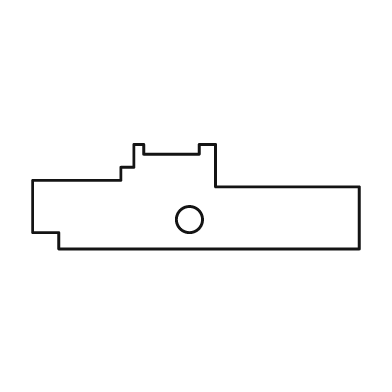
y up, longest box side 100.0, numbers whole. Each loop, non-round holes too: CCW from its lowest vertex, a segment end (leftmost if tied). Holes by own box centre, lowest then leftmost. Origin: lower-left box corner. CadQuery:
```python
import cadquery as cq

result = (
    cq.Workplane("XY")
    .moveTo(8.0, 0.0)
    .lineTo(100.0, 0.0)
    .lineTo(100.0, 19.0)
    .lineTo(56.0, 19.0)
    .lineTo(56.0, 32.0)
    .lineTo(51.0, 32.0)
    .lineTo(51.0, 29.0)
    .lineTo(34.0, 29.0)
    .lineTo(34.0, 32.0)
    .lineTo(31.0, 32.0)
    .lineTo(31.0, 25.0)
    .lineTo(27.0, 25.0)
    .lineTo(27.0, 21.0)
    .lineTo(0.0, 21.0)
    .lineTo(0.0, 5.0)
    .lineTo(8.0, 5.0)
    .close()
    .moveTo(48.0, 9.0)
    .circle(4.0)
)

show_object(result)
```